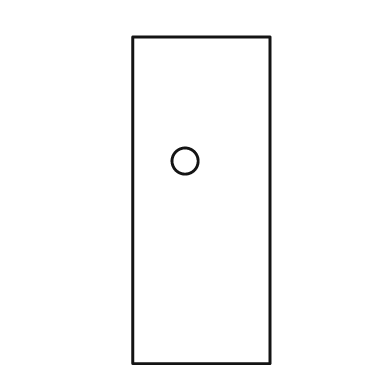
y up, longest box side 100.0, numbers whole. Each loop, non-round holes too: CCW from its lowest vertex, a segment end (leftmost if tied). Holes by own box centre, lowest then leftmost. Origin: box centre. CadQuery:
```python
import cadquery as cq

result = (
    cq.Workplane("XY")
    .moveTo(-21.0, -50.0)
    .lineTo(21.0, -50.0)
    .lineTo(21.0, 50.0)
    .lineTo(-21.0, 50.0)
    .close()
    .moveTo(-5.0, 12.0)
    .circle(4.0)
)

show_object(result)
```